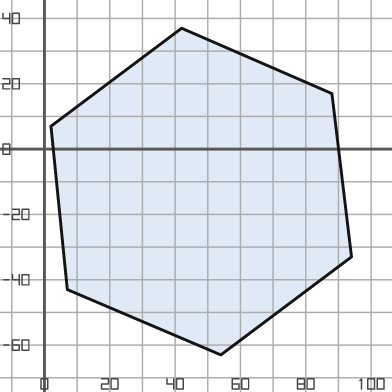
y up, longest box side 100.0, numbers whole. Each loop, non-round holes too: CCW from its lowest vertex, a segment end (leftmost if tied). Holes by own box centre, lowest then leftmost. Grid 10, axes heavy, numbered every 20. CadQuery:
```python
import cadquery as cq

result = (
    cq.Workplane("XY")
    .moveTo(54.0, -63.0)
    .lineTo(94.0, -33.0)
    .lineTo(88.0, 17.0)
    .lineTo(42.0, 37.0)
    .lineTo(2.0, 7.0)
    .lineTo(7.0, -43.0)
    .close()
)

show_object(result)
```